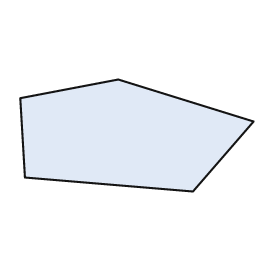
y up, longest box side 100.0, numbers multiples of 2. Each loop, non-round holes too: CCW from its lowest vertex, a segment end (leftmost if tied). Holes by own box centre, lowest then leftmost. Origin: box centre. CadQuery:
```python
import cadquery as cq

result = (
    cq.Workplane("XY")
    .moveTo(24.0, -24.0)
    .lineTo(50.0, 6.0)
    .lineTo(-8.0, 24.0)
    .lineTo(-50.0, 16.0)
    .lineTo(-48.0, -18.0)
    .close()
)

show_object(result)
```